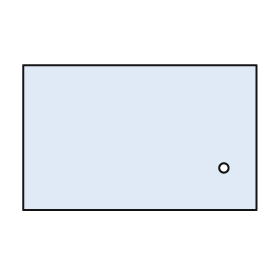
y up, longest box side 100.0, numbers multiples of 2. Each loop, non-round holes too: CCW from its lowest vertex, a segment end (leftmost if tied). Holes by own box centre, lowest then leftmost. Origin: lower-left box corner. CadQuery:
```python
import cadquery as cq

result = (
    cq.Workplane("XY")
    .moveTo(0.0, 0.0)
    .lineTo(100.0, 0.0)
    .lineTo(100.0, 62.0)
    .lineTo(0.0, 62.0)
    .close()
    .moveTo(86.0, 18.0)
    .circle(2.0)
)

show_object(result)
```